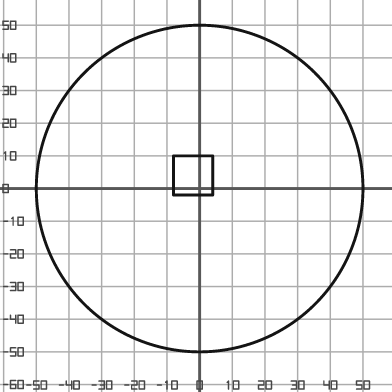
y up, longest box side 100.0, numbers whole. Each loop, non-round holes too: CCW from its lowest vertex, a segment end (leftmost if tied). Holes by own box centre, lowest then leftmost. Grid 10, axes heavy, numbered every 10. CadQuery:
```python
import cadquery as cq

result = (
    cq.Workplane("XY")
    .moveTo(0.0, 0.0)
    .circle(50.0)
    .moveTo(-8.0, -2.0)
    .lineTo(4.0, -2.0)
    .lineTo(4.0, 10.0)
    .lineTo(-8.0, 10.0)
    .close()
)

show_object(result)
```